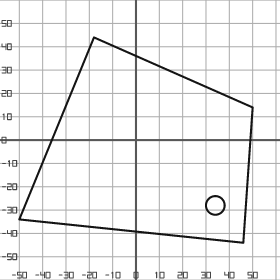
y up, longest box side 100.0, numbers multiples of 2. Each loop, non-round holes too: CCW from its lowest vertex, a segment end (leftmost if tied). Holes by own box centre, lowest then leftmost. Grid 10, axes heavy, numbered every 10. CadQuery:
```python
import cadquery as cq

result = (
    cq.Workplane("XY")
    .moveTo(46.0, -44.0)
    .lineTo(50.0, 14.0)
    .lineTo(-18.0, 44.0)
    .lineTo(-50.0, -34.0)
    .close()
    .moveTo(34.0, -28.0)
    .circle(4.0)
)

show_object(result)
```